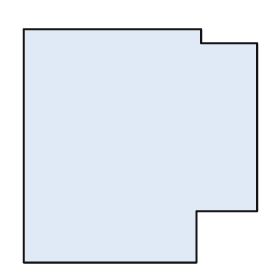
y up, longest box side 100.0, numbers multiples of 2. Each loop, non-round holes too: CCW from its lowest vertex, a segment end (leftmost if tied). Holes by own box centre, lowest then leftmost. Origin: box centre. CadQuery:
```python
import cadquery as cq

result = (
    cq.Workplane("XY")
    .moveTo(-50.0, -50.0)
    .lineTo(24.0, -50.0)
    .lineTo(24.0, -28.0)
    .lineTo(50.0, -28.0)
    .lineTo(50.0, 44.0)
    .lineTo(26.0, 44.0)
    .lineTo(26.0, 50.0)
    .lineTo(-50.0, 50.0)
    .close()
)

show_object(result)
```